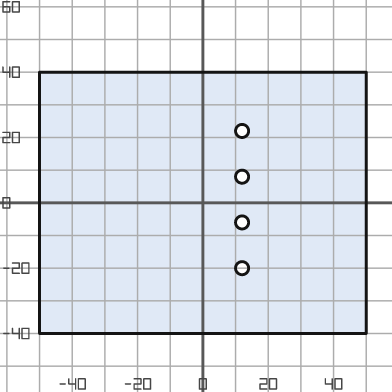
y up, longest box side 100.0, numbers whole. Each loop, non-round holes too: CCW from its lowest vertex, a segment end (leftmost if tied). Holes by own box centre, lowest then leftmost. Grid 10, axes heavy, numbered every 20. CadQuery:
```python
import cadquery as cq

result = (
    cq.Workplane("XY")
    .moveTo(-50.0, -40.0)
    .lineTo(50.0, -40.0)
    .lineTo(50.0, 40.0)
    .lineTo(-50.0, 40.0)
    .close()
    .moveTo(12.0, -20.0)
    .circle(2.0)
    .moveTo(12.0, -6.0)
    .circle(2.0)
    .moveTo(12.0, 8.0)
    .circle(2.0)
    .moveTo(12.0, 22.0)
    .circle(2.0)
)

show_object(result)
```